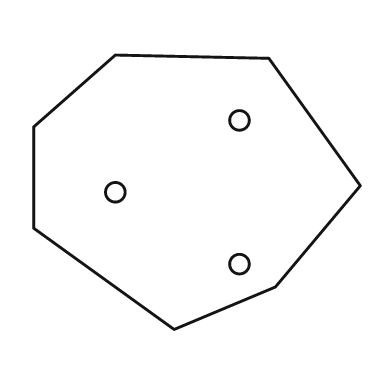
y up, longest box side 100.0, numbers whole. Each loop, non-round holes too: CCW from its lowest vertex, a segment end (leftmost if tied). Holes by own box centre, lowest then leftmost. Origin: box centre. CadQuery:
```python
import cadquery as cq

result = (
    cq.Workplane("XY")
    .moveTo(-7.0, -42.0)
    .lineTo(24.0, -29.0)
    .lineTo(50.0, 2.0)
    .lineTo(22.0, 41.0)
    .lineTo(-25.0, 42.0)
    .lineTo(-50.0, 20.0)
    .lineTo(-50.0, -11.0)
    .close()
    .moveTo(13.0, -22.0)
    .circle(3.0)
    .moveTo(-25.0, 0.0)
    .circle(3.0)
    .moveTo(13.0, 22.0)
    .circle(3.0)
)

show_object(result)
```